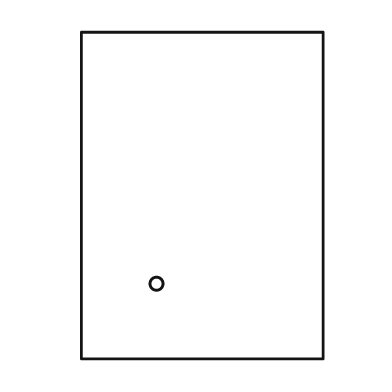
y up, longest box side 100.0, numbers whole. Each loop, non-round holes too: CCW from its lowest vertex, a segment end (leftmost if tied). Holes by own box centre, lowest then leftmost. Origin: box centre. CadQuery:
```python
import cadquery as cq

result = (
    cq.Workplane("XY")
    .moveTo(-37.0, -50.0)
    .lineTo(37.0, -50.0)
    .lineTo(37.0, 50.0)
    .lineTo(-37.0, 50.0)
    .close()
    .moveTo(-14.0, -27.0)
    .circle(2.0)
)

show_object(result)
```